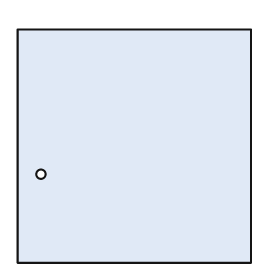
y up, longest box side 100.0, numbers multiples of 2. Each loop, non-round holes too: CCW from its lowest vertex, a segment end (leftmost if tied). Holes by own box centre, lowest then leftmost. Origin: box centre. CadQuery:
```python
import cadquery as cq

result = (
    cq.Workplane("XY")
    .moveTo(-50.0, -50.0)
    .lineTo(50.0, -50.0)
    .lineTo(50.0, 50.0)
    .lineTo(-50.0, 50.0)
    .close()
    .moveTo(-40.0, -12.0)
    .circle(2.0)
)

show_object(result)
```